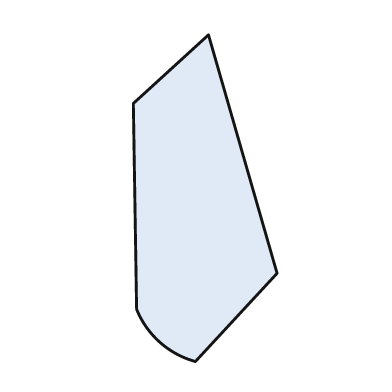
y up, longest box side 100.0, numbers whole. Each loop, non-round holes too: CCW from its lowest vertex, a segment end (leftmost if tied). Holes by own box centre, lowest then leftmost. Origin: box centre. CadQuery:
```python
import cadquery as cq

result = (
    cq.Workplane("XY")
    .moveTo(-3.0, -50.0)
    .lineTo(22.0, -23.0)
    .lineTo(1.0, 50.0)
    .lineTo(-22.0, 29.0)
    .lineTo(-21.0, -34.0)
    .threePointArc((-14.0, -44.0), (-3.0, -50.0))
    .close()
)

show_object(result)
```